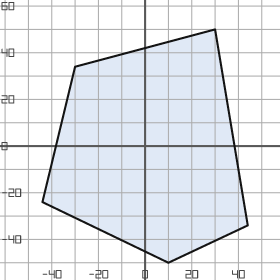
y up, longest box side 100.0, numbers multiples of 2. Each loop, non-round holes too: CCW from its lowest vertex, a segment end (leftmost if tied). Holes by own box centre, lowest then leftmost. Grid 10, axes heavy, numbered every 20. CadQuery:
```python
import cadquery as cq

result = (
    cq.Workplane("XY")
    .moveTo(10.0, -50.0)
    .lineTo(44.0, -34.0)
    .lineTo(30.0, 50.0)
    .lineTo(-30.0, 34.0)
    .lineTo(-44.0, -24.0)
    .close()
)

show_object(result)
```